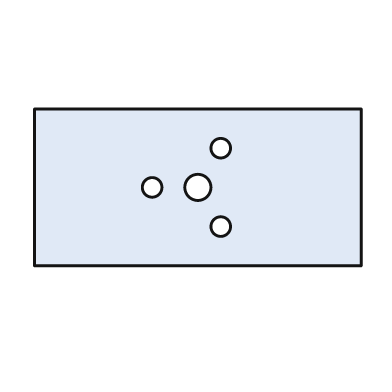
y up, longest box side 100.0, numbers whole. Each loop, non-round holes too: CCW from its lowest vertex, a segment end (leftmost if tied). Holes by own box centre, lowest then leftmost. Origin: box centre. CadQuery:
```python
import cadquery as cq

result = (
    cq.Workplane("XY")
    .moveTo(-50.0, -24.0)
    .lineTo(50.0, -24.0)
    .lineTo(50.0, 24.0)
    .lineTo(-50.0, 24.0)
    .close()
    .moveTo(7.0, -12.0)
    .circle(3.0)
    .moveTo(-14.0, 0.0)
    .circle(3.0)
    .moveTo(0.0, 0.0)
    .circle(4.0)
    .moveTo(7.0, 12.0)
    .circle(3.0)
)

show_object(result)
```